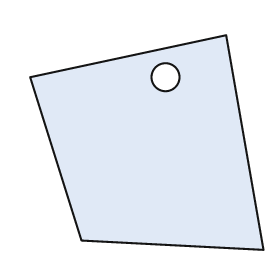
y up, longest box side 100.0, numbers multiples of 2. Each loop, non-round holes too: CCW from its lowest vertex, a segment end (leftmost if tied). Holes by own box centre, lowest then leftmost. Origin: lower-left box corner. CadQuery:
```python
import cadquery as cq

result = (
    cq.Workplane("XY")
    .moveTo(100.0, 0.0)
    .lineTo(84.0, 92.0)
    .lineTo(0.0, 74.0)
    .lineTo(22.0, 4.0)
    .close()
    .moveTo(58.0, 74.0)
    .circle(6.0)
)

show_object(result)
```